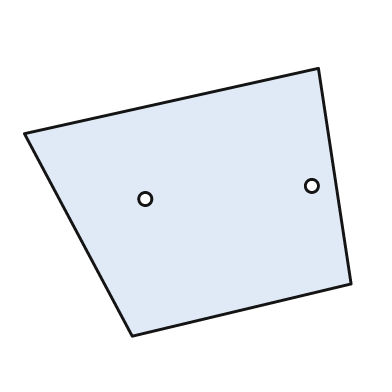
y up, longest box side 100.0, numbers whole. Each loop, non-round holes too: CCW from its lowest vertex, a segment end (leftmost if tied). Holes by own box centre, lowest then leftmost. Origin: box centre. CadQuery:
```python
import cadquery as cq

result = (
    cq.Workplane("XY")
    .moveTo(-17.0, -41.0)
    .lineTo(50.0, -25.0)
    .lineTo(40.0, 41.0)
    .lineTo(-50.0, 21.0)
    .close()
    .moveTo(-13.0, 1.0)
    .circle(2.0)
    .moveTo(38.0, 5.0)
    .circle(2.0)
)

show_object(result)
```